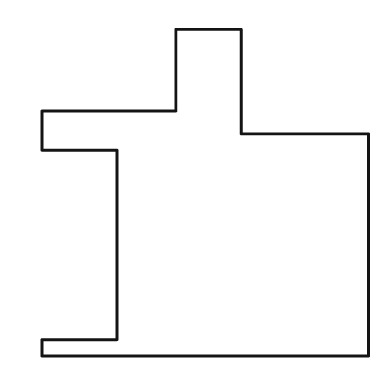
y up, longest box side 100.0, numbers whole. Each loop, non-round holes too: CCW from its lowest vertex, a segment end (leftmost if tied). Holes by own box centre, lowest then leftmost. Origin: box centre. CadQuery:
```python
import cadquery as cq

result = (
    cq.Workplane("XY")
    .moveTo(-50.0, -50.0)
    .lineTo(50.0, -50.0)
    .lineTo(50.0, 18.0)
    .lineTo(11.0, 18.0)
    .lineTo(11.0, 50.0)
    .lineTo(-9.0, 50.0)
    .lineTo(-9.0, 25.0)
    .lineTo(-50.0, 25.0)
    .lineTo(-50.0, 13.0)
    .lineTo(-27.0, 13.0)
    .lineTo(-27.0, -45.0)
    .lineTo(-50.0, -45.0)
    .close()
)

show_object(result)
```